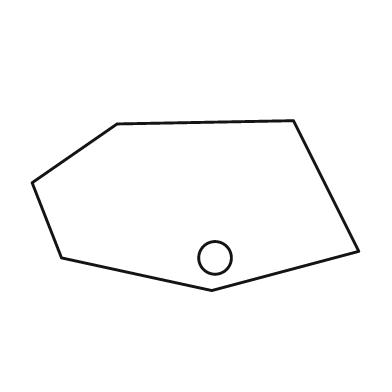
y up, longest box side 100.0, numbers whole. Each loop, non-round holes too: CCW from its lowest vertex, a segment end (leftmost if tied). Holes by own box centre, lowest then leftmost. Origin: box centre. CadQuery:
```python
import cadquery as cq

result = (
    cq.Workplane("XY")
    .moveTo(5.0, -26.0)
    .lineTo(50.0, -14.0)
    .lineTo(30.0, 26.0)
    .lineTo(-24.0, 25.0)
    .lineTo(-50.0, 7.0)
    .lineTo(-41.0, -16.0)
    .close()
    .moveTo(6.0, -16.0)
    .circle(5.0)
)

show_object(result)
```